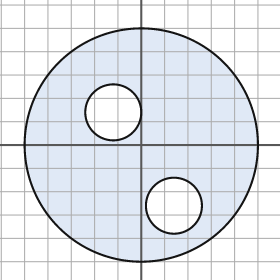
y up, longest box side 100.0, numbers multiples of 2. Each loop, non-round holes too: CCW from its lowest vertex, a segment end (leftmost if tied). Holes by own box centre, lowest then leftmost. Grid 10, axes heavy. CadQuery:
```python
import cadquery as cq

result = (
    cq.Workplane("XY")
    .moveTo(0.0, 0.0)
    .circle(50.0)
    .moveTo(14.0, -26.0)
    .circle(12.0)
    .moveTo(-12.0, 14.0)
    .circle(12.0)
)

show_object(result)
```